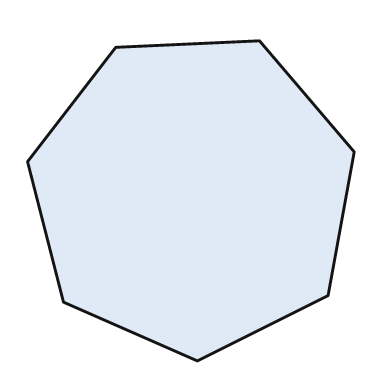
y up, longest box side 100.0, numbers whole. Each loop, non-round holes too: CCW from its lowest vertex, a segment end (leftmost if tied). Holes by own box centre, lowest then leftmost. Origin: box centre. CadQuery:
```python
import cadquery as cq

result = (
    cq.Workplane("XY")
    .moveTo(2.0, -49.0)
    .lineTo(42.0, -29.0)
    .lineTo(50.0, 15.0)
    .lineTo(21.0, 49.0)
    .lineTo(-23.0, 47.0)
    .lineTo(-50.0, 12.0)
    .lineTo(-39.0, -31.0)
    .close()
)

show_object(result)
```